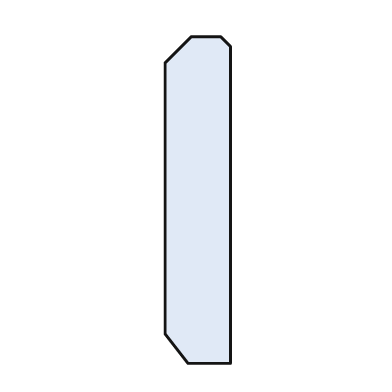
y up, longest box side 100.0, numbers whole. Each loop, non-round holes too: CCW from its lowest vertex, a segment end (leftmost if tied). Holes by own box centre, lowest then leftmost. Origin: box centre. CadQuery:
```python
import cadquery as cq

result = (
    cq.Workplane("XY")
    .moveTo(-3.0, -50.0)
    .lineTo(10.0, -50.0)
    .lineTo(10.0, 47.0)
    .lineTo(7.0, 50.0)
    .lineTo(-2.0, 50.0)
    .lineTo(-10.0, 42.0)
    .lineTo(-10.0, -41.0)
    .close()
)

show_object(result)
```